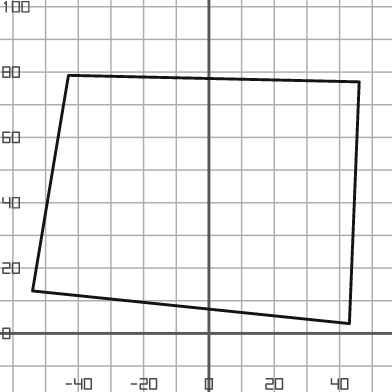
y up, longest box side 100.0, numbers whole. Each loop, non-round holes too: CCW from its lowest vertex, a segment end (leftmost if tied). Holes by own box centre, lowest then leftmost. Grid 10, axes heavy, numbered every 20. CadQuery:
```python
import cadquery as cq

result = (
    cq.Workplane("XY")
    .moveTo(43.0, 3.0)
    .lineTo(46.0, 77.0)
    .lineTo(-43.0, 79.0)
    .lineTo(-54.0, 13.0)
    .close()
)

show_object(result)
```